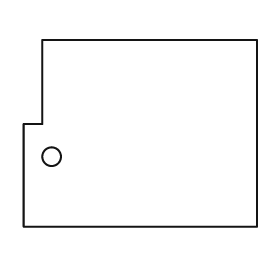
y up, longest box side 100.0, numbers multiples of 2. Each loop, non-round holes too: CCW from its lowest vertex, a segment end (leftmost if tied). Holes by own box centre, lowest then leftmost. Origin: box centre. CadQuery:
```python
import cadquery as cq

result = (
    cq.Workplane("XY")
    .moveTo(-50.0, -40.0)
    .lineTo(50.0, -40.0)
    .lineTo(50.0, 40.0)
    .lineTo(-42.0, 40.0)
    .lineTo(-42.0, 4.0)
    .lineTo(-50.0, 4.0)
    .close()
    .moveTo(-38.0, -10.0)
    .circle(4.0)
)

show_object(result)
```